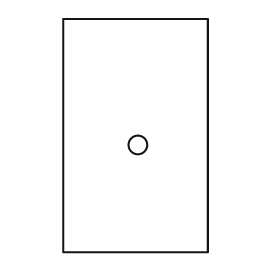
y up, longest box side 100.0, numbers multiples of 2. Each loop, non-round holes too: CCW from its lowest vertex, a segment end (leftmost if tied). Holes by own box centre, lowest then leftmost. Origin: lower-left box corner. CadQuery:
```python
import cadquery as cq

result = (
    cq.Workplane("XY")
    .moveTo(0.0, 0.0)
    .lineTo(62.0, 0.0)
    .lineTo(62.0, 100.0)
    .lineTo(0.0, 100.0)
    .close()
    .moveTo(32.0, 46.0)
    .circle(4.0)
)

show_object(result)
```